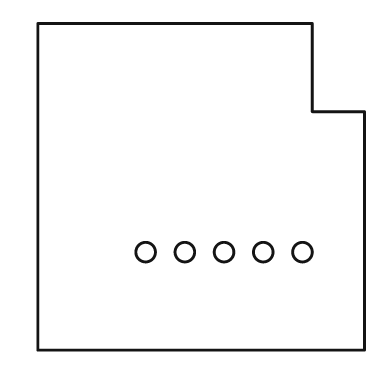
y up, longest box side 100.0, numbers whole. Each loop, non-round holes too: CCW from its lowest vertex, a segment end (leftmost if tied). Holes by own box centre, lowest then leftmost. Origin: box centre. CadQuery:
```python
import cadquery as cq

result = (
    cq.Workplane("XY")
    .moveTo(-50.0, -50.0)
    .lineTo(50.0, -50.0)
    .lineTo(50.0, 23.0)
    .lineTo(34.0, 23.0)
    .lineTo(34.0, 50.0)
    .lineTo(-50.0, 50.0)
    .close()
    .moveTo(-17.0, -20.0)
    .circle(3.0)
    .moveTo(-5.0, -20.0)
    .circle(3.0)
    .moveTo(7.0, -20.0)
    .circle(3.0)
    .moveTo(19.0, -20.0)
    .circle(3.0)
    .moveTo(31.0, -20.0)
    .circle(3.0)
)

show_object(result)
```